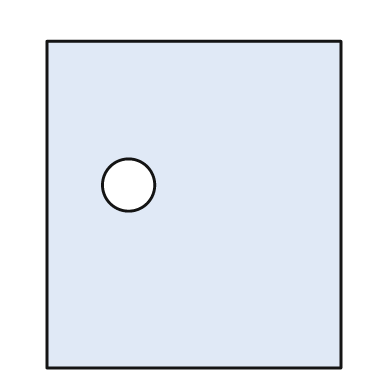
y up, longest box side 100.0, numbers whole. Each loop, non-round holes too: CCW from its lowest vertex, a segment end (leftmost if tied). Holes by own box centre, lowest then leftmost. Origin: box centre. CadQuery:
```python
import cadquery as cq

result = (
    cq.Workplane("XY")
    .moveTo(-45.0, -50.0)
    .lineTo(45.0, -50.0)
    .lineTo(45.0, 50.0)
    .lineTo(-45.0, 50.0)
    .close()
    .moveTo(-20.0, 6.0)
    .circle(8.0)
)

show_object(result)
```